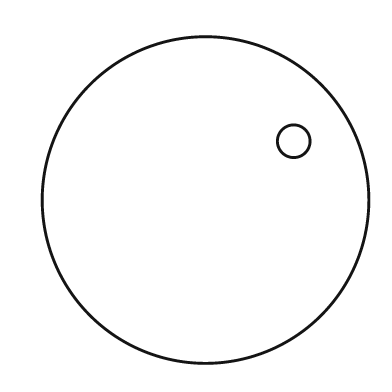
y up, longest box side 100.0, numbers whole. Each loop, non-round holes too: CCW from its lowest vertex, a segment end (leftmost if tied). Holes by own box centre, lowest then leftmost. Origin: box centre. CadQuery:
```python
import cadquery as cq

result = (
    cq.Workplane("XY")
    .moveTo(0.0, 0.0)
    .circle(50.0)
    .moveTo(27.0, 18.0)
    .circle(5.0)
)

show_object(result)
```